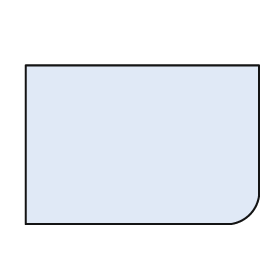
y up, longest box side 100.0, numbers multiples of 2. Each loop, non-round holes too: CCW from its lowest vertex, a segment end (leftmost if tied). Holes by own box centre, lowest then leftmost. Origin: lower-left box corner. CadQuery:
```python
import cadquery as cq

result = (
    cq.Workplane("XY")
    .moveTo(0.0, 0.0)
    .lineTo(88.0, 0.0)
    .threePointArc((96.0, 4.0), (100.0, 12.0))
    .lineTo(100.0, 68.0)
    .lineTo(0.0, 68.0)
    .close()
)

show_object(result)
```